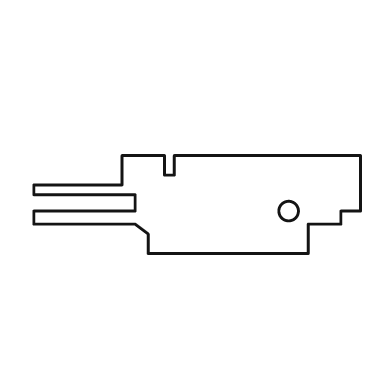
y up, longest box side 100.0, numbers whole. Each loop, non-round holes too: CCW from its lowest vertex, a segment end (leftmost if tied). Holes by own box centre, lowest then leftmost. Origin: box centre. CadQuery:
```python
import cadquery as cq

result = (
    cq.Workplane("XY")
    .moveTo(-15.0, -15.0)
    .lineTo(34.0, -15.0)
    .lineTo(34.0, -6.0)
    .lineTo(44.0, -6.0)
    .lineTo(44.0, -2.0)
    .lineTo(50.0, -2.0)
    .lineTo(50.0, 15.0)
    .lineTo(-7.0, 15.0)
    .lineTo(-7.0, 9.0)
    .lineTo(-10.0, 9.0)
    .lineTo(-10.0, 15.0)
    .lineTo(-23.0, 15.0)
    .lineTo(-23.0, 6.0)
    .lineTo(-50.0, 6.0)
    .lineTo(-50.0, 3.0)
    .lineTo(-19.0, 3.0)
    .lineTo(-19.0, -2.0)
    .lineTo(-50.0, -2.0)
    .lineTo(-50.0, -6.0)
    .lineTo(-19.0, -6.0)
    .lineTo(-15.0, -9.0)
    .close()
    .moveTo(28.0, -2.0)
    .circle(3.0)
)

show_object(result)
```